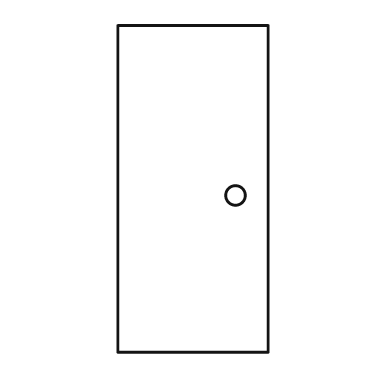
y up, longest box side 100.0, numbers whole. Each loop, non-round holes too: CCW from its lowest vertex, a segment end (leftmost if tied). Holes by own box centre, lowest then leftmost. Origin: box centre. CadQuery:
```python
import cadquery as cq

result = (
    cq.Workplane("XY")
    .moveTo(-23.0, -50.0)
    .lineTo(23.0, -50.0)
    .lineTo(23.0, 50.0)
    .lineTo(-23.0, 50.0)
    .close()
    .moveTo(13.0, -2.0)
    .circle(3.0)
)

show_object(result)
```